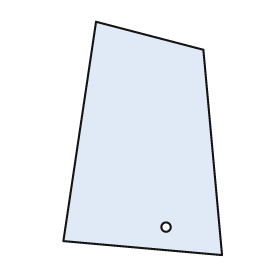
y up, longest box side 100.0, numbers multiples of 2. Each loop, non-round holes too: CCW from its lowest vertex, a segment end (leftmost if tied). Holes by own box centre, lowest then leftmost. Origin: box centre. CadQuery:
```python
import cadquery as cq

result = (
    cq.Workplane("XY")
    .moveTo(34.0, -50.0)
    .lineTo(26.0, 38.0)
    .lineTo(-20.0, 50.0)
    .lineTo(-34.0, -44.0)
    .close()
    .moveTo(10.0, -38.0)
    .circle(2.0)
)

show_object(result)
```